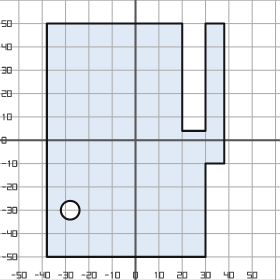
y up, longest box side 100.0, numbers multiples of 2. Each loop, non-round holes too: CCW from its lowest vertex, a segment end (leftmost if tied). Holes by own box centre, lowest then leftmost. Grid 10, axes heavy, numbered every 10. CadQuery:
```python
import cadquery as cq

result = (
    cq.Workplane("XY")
    .moveTo(-38.0, -50.0)
    .lineTo(30.0, -50.0)
    .lineTo(30.0, -10.0)
    .lineTo(38.0, -10.0)
    .lineTo(38.0, 50.0)
    .lineTo(30.0, 50.0)
    .lineTo(30.0, 4.0)
    .lineTo(20.0, 4.0)
    .lineTo(20.0, 50.0)
    .lineTo(-38.0, 50.0)
    .close()
    .moveTo(-28.0, -30.0)
    .circle(4.0)
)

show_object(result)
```